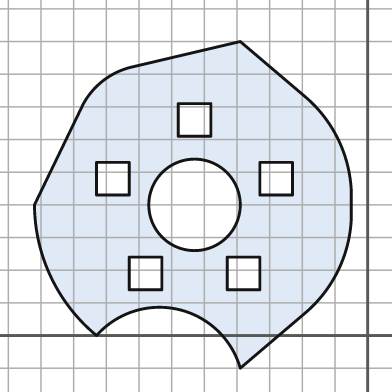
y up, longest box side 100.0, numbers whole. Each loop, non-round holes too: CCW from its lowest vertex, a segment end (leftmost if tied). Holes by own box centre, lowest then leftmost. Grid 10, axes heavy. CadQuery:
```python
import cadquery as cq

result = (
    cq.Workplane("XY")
    .moveTo(-39.0, -10.0)
    .lineTo(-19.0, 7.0)
    .threePointArc((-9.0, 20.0), (-5.0, 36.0))
    .lineTo(-5.0, 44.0)
    .threePointArc((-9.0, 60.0), (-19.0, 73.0))
    .lineTo(-39.0, 90.0)
    .lineTo(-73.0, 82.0)
    .threePointArc((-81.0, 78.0), (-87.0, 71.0))
    .lineTo(-102.0, 40.0)
    .threePointArc((-97.0, 18.0), (-83.0, 0.0))
    .threePointArc((-58.0, 8.0), (-39.0, -10.0))
    .close()
    .moveTo(-73.0, 14.0)
    .lineTo(-63.0, 14.0)
    .lineTo(-63.0, 24.0)
    .lineTo(-73.0, 24.0)
    .close()
    .moveTo(-43.0, 14.0)
    .lineTo(-33.0, 14.0)
    .lineTo(-33.0, 24.0)
    .lineTo(-43.0, 24.0)
    .close()
    .moveTo(-53.0, 40.0)
    .circle(14.0)
    .moveTo(-83.0, 43.0)
    .lineTo(-73.0, 43.0)
    .lineTo(-73.0, 53.0)
    .lineTo(-83.0, 53.0)
    .close()
    .moveTo(-33.0, 43.0)
    .lineTo(-23.0, 43.0)
    .lineTo(-23.0, 53.0)
    .lineTo(-33.0, 53.0)
    .close()
    .moveTo(-58.0, 61.0)
    .lineTo(-48.0, 61.0)
    .lineTo(-48.0, 71.0)
    .lineTo(-58.0, 71.0)
    .close()
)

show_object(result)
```